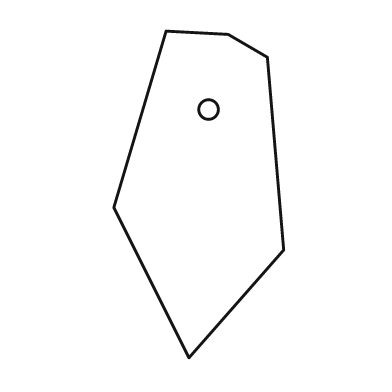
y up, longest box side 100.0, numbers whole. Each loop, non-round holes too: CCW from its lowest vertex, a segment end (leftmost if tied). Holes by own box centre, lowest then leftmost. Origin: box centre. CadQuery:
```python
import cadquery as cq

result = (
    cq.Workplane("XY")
    .moveTo(-3.0, -50.0)
    .lineTo(26.0, -17.0)
    .lineTo(21.0, 42.0)
    .lineTo(9.0, 49.0)
    .lineTo(-10.0, 50.0)
    .lineTo(-26.0, -4.0)
    .close()
    .moveTo(3.0, 26.0)
    .circle(3.0)
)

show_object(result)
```